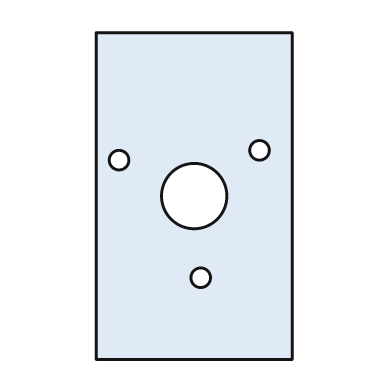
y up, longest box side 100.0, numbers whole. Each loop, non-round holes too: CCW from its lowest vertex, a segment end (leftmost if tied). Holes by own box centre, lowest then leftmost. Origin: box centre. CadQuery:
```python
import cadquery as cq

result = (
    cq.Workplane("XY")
    .moveTo(-30.0, -50.0)
    .lineTo(30.0, -50.0)
    .lineTo(30.0, 50.0)
    .lineTo(-30.0, 50.0)
    .close()
    .moveTo(2.0, -25.0)
    .circle(3.0)
    .moveTo(0.0, 0.0)
    .circle(10.0)
    .moveTo(-23.0, 11.0)
    .circle(3.0)
    .moveTo(20.0, 14.0)
    .circle(3.0)
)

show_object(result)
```